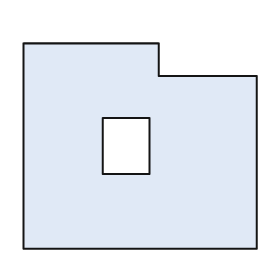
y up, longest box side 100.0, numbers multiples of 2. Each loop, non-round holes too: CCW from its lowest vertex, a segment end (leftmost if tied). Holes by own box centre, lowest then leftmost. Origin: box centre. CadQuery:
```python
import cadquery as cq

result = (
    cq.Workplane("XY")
    .moveTo(-50.0, -44.0)
    .lineTo(50.0, -44.0)
    .lineTo(50.0, 30.0)
    .lineTo(8.0, 30.0)
    .lineTo(8.0, 44.0)
    .lineTo(-50.0, 44.0)
    .close()
    .moveTo(-16.0, -12.0)
    .lineTo(4.0, -12.0)
    .lineTo(4.0, 12.0)
    .lineTo(-16.0, 12.0)
    .close()
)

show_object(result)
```